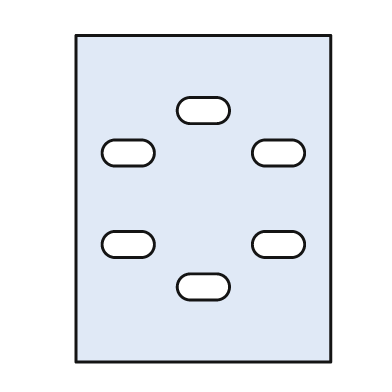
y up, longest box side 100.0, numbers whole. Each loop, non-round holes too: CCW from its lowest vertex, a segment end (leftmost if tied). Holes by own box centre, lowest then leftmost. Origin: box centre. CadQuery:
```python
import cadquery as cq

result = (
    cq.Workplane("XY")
    .moveTo(-39.0, -50.0)
    .lineTo(39.0, -50.0)
    .lineTo(39.0, 50.0)
    .lineTo(-39.0, 50.0)
    .close()
    .moveTo(-4.0, -31.0)
    .lineTo(4.0, -31.0)
    .threePointArc((8.0, -27.0), (4.0, -23.0))
    .lineTo(-4.0, -23.0)
    .threePointArc((-8.0, -27.0), (-4.0, -31.0))
    .close()
    .moveTo(-27.0, -18.0)
    .lineTo(-19.0, -18.0)
    .threePointArc((-15.0, -14.0), (-19.0, -10.0))
    .lineTo(-27.0, -10.0)
    .threePointArc((-31.0, -14.0), (-27.0, -18.0))
    .close()
    .moveTo(19.0, -18.0)
    .lineTo(27.0, -18.0)
    .threePointArc((31.0, -14.0), (27.0, -10.0))
    .lineTo(19.0, -10.0)
    .threePointArc((15.0, -14.0), (19.0, -18.0))
    .close()
    .moveTo(-27.0, 10.0)
    .lineTo(-19.0, 10.0)
    .threePointArc((-15.0, 14.0), (-19.0, 18.0))
    .lineTo(-27.0, 18.0)
    .threePointArc((-31.0, 14.0), (-27.0, 10.0))
    .close()
    .moveTo(19.0, 10.0)
    .lineTo(27.0, 10.0)
    .threePointArc((31.0, 14.0), (27.0, 18.0))
    .lineTo(19.0, 18.0)
    .threePointArc((15.0, 14.0), (19.0, 10.0))
    .close()
    .moveTo(-4.0, 23.0)
    .lineTo(4.0, 23.0)
    .threePointArc((8.0, 27.0), (4.0, 31.0))
    .lineTo(-4.0, 31.0)
    .threePointArc((-8.0, 27.0), (-4.0, 23.0))
    .close()
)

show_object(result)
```